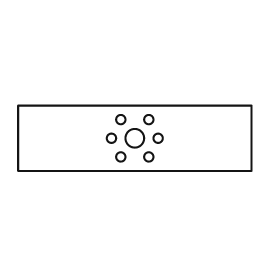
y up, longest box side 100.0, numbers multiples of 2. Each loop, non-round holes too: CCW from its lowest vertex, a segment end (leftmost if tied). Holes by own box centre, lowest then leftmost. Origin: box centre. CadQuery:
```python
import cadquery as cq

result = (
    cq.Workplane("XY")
    .moveTo(-50.0, -14.0)
    .lineTo(50.0, -14.0)
    .lineTo(50.0, 14.0)
    .lineTo(-50.0, 14.0)
    .close()
    .moveTo(-6.0, -8.0)
    .circle(2.0)
    .moveTo(6.0, -8.0)
    .circle(2.0)
    .moveTo(-10.0, 0.0)
    .circle(2.0)
    .moveTo(0.0, 0.0)
    .circle(4.0)
    .moveTo(10.0, 0.0)
    .circle(2.0)
    .moveTo(-6.0, 8.0)
    .circle(2.0)
    .moveTo(6.0, 8.0)
    .circle(2.0)
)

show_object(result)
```